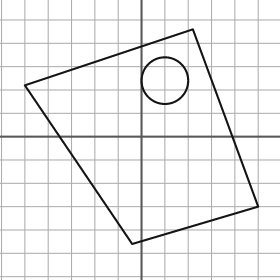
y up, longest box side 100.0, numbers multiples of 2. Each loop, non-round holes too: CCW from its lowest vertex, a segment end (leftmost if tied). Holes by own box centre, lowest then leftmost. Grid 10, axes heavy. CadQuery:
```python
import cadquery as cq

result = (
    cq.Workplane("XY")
    .moveTo(-4.0, -46.0)
    .lineTo(50.0, -30.0)
    .lineTo(22.0, 46.0)
    .lineTo(-50.0, 22.0)
    .close()
    .moveTo(10.0, 24.0)
    .circle(10.0)
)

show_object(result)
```